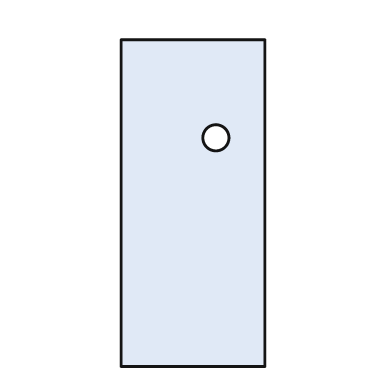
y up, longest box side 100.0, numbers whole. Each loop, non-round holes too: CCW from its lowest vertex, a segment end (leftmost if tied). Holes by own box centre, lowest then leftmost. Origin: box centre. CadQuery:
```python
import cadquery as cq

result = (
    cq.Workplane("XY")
    .moveTo(-22.0, -50.0)
    .lineTo(22.0, -50.0)
    .lineTo(22.0, 50.0)
    .lineTo(-22.0, 50.0)
    .close()
    .moveTo(7.0, 20.0)
    .circle(4.0)
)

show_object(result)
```